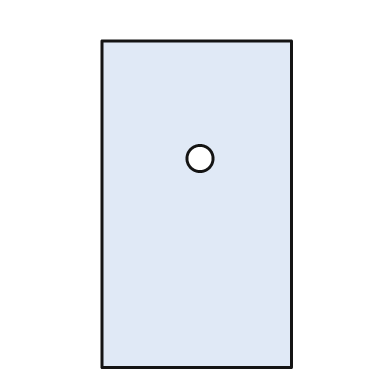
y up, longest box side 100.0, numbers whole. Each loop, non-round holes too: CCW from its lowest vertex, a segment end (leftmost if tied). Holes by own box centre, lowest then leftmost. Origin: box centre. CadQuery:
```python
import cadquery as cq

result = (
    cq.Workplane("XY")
    .moveTo(-29.0, -50.0)
    .lineTo(29.0, -50.0)
    .lineTo(29.0, 50.0)
    .lineTo(-29.0, 50.0)
    .close()
    .moveTo(1.0, 14.0)
    .circle(4.0)
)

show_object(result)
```